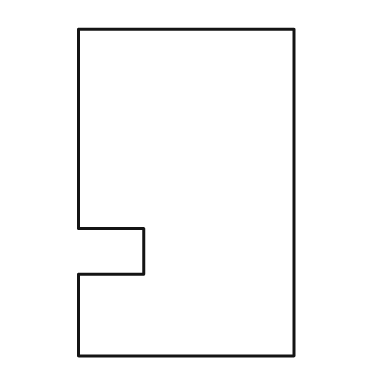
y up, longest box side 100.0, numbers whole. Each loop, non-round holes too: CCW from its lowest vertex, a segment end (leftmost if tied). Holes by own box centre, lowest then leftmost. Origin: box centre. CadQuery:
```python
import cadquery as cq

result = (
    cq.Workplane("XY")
    .moveTo(-33.0, -50.0)
    .lineTo(33.0, -50.0)
    .lineTo(33.0, 50.0)
    .lineTo(-33.0, 50.0)
    .lineTo(-33.0, -11.0)
    .lineTo(-13.0, -11.0)
    .lineTo(-13.0, -25.0)
    .lineTo(-33.0, -25.0)
    .close()
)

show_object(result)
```